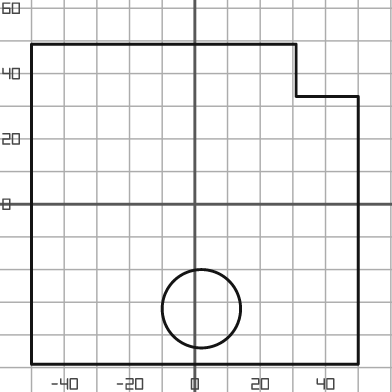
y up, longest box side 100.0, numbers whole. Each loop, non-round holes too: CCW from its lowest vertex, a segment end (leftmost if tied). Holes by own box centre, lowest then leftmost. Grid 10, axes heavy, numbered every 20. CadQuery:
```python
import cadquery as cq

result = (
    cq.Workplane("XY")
    .moveTo(-50.0, -49.0)
    .lineTo(50.0, -49.0)
    .lineTo(50.0, 33.0)
    .lineTo(31.0, 33.0)
    .lineTo(31.0, 49.0)
    .lineTo(-50.0, 49.0)
    .close()
    .moveTo(2.0, -32.0)
    .circle(12.0)
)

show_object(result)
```